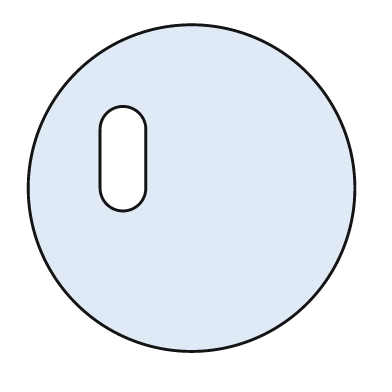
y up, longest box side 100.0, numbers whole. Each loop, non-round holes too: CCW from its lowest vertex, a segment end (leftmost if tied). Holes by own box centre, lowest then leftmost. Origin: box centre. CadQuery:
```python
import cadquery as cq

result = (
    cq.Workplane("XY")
    .moveTo(0.0, 0.0)
    .circle(50.0)
    .moveTo(-28.0, 0.0)
    .threePointArc((-21.0, -7.0), (-14.0, 0.0))
    .lineTo(-14.0, 18.0)
    .threePointArc((-21.0, 25.0), (-28.0, 18.0))
    .close()
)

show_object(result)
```